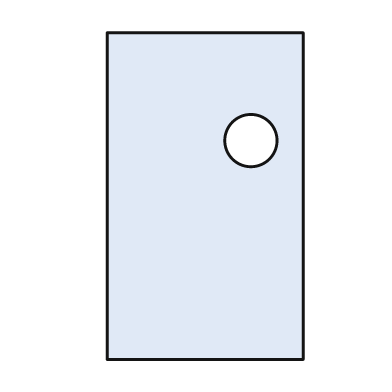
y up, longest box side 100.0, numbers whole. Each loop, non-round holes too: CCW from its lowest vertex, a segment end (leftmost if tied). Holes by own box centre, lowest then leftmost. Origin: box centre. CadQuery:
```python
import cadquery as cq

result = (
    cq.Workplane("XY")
    .moveTo(-30.0, -50.0)
    .lineTo(30.0, -50.0)
    .lineTo(30.0, 50.0)
    .lineTo(-30.0, 50.0)
    .close()
    .moveTo(14.0, 17.0)
    .circle(8.0)
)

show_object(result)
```